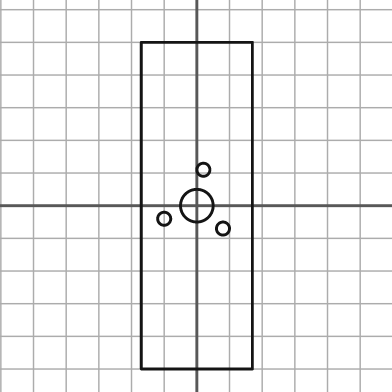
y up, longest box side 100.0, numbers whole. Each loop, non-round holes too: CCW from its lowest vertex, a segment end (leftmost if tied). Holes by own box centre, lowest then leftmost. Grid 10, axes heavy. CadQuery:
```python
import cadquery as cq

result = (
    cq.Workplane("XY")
    .moveTo(-17.0, -50.0)
    .lineTo(17.0, -50.0)
    .lineTo(17.0, 50.0)
    .lineTo(-17.0, 50.0)
    .close()
    .moveTo(8.0, -7.0)
    .circle(2.0)
    .moveTo(-10.0, -4.0)
    .circle(2.0)
    .moveTo(0.0, 0.0)
    .circle(5.0)
    .moveTo(2.0, 11.0)
    .circle(2.0)
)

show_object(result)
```